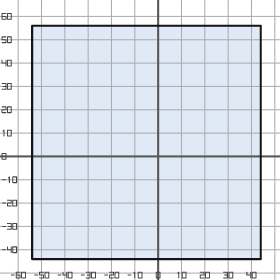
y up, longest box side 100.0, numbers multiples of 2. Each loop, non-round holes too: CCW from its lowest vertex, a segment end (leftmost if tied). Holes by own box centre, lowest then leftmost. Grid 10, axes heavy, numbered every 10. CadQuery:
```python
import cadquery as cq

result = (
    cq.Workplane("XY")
    .moveTo(-54.0, -44.0)
    .lineTo(44.0, -44.0)
    .lineTo(44.0, 56.0)
    .lineTo(-54.0, 56.0)
    .close()
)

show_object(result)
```